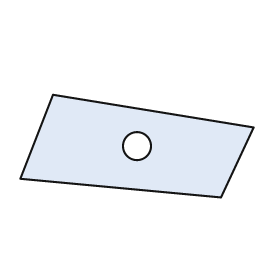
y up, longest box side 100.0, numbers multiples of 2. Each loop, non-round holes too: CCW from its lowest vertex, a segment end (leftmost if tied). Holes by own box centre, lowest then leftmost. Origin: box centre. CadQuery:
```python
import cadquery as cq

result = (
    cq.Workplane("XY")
    .moveTo(36.0, -22.0)
    .lineTo(50.0, 8.0)
    .lineTo(-36.0, 22.0)
    .lineTo(-50.0, -14.0)
    .close()
    .moveTo(0.0, 0.0)
    .circle(6.0)
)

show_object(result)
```